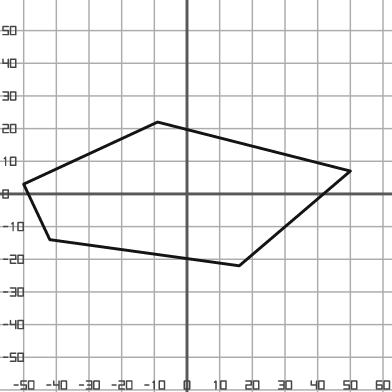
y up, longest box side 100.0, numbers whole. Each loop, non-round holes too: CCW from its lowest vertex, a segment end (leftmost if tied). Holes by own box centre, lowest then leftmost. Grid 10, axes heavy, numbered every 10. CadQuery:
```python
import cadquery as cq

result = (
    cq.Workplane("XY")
    .moveTo(16.0, -22.0)
    .lineTo(50.0, 7.0)
    .lineTo(-9.0, 22.0)
    .lineTo(-50.0, 3.0)
    .lineTo(-42.0, -14.0)
    .close()
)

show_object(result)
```